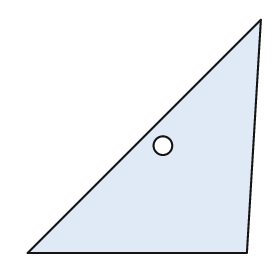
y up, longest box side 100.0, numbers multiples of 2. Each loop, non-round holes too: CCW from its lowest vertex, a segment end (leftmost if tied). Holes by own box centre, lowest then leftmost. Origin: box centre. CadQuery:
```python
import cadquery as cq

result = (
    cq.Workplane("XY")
    .moveTo(-50.0, -50.0)
    .lineTo(44.0, -50.0)
    .lineTo(50.0, 50.0)
    .close()
    .moveTo(8.0, -4.0)
    .circle(4.0)
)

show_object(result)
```